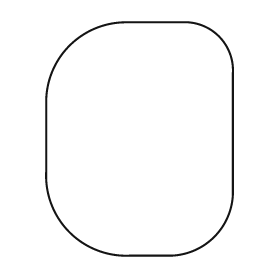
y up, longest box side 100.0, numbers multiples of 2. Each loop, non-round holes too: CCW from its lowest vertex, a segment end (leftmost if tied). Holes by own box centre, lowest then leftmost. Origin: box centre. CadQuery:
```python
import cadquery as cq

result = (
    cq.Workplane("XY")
    .moveTo(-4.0, -50.0)
    .lineTo(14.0, -50.0)
    .threePointArc((32.0, -42.0), (40.0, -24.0))
    .lineTo(40.0, 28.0)
    .threePointArc((34.0, 44.0), (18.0, 50.0))
    .lineTo(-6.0, 50.0)
    .threePointArc((-30.0, 40.0), (-40.0, 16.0))
    .lineTo(-40.0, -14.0)
    .threePointArc((-30.0, -40.0), (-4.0, -50.0))
    .close()
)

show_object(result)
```